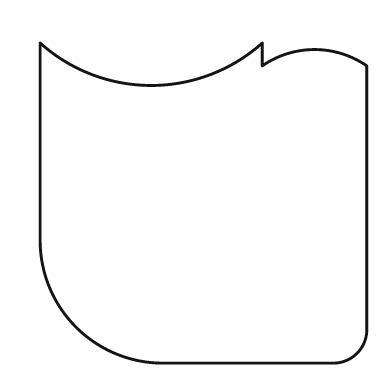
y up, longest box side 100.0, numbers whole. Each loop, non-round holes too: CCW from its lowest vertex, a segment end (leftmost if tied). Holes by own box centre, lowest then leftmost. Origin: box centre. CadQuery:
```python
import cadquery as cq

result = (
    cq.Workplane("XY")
    .moveTo(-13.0, -49.0)
    .lineTo(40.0, -49.0)
    .threePointArc((47.0, -46.0), (50.0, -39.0))
    .lineTo(50.0, 42.0)
    .threePointArc((34.0, 47.0), (18.0, 42.0))
    .lineTo(18.0, 49.0)
    .threePointArc((-16.0, 36.0), (-50.0, 49.0))
    .lineTo(-50.0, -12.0)
    .threePointArc((-39.0, -38.0), (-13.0, -49.0))
    .close()
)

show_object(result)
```